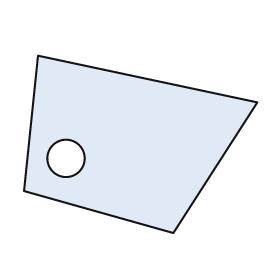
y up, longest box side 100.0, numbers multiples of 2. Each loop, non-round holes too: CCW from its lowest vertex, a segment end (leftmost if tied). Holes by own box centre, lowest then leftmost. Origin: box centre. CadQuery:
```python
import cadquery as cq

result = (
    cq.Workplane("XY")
    .moveTo(14.0, -38.0)
    .lineTo(50.0, 18.0)
    .lineTo(-44.0, 38.0)
    .lineTo(-50.0, -20.0)
    .close()
    .moveTo(-32.0, -6.0)
    .circle(8.0)
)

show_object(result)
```